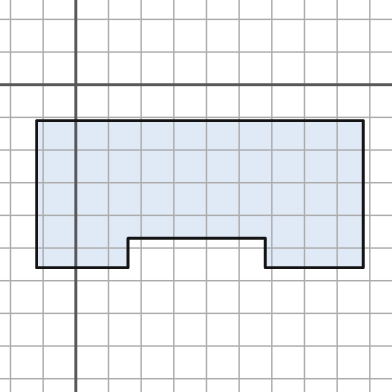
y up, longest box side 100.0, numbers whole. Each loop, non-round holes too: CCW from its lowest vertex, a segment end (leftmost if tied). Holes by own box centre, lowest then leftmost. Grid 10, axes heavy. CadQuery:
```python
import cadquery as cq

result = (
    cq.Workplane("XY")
    .moveTo(-12.0, -56.0)
    .lineTo(16.0, -56.0)
    .lineTo(16.0, -47.0)
    .lineTo(58.0, -47.0)
    .lineTo(58.0, -56.0)
    .lineTo(88.0, -56.0)
    .lineTo(88.0, -11.0)
    .lineTo(-12.0, -11.0)
    .close()
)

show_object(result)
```